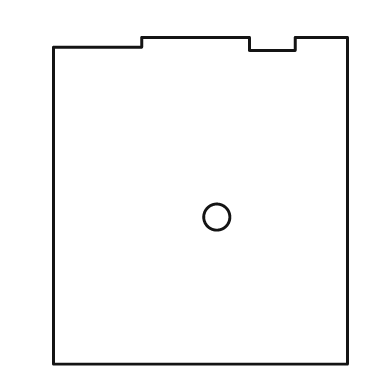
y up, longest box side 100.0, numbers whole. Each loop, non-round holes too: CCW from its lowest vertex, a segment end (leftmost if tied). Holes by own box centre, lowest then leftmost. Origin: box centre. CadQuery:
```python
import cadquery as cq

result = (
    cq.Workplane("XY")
    .moveTo(-45.0, -50.0)
    .lineTo(45.0, -50.0)
    .lineTo(45.0, 50.0)
    .lineTo(29.0, 50.0)
    .lineTo(29.0, 46.0)
    .lineTo(15.0, 46.0)
    .lineTo(15.0, 50.0)
    .lineTo(-18.0, 50.0)
    .lineTo(-18.0, 47.0)
    .lineTo(-45.0, 47.0)
    .close()
    .moveTo(5.0, -5.0)
    .circle(4.0)
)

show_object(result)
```